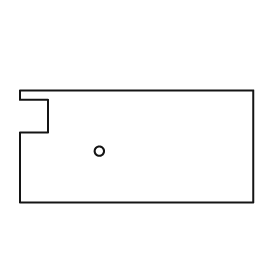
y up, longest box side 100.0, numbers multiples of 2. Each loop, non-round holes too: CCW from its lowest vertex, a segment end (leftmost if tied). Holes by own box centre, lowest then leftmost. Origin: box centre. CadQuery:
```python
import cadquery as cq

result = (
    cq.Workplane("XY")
    .moveTo(-50.0, -24.0)
    .lineTo(50.0, -24.0)
    .lineTo(50.0, 24.0)
    .lineTo(-50.0, 24.0)
    .lineTo(-50.0, 20.0)
    .lineTo(-38.0, 20.0)
    .lineTo(-38.0, 6.0)
    .lineTo(-50.0, 6.0)
    .close()
    .moveTo(-16.0, -2.0)
    .circle(2.0)
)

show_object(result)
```